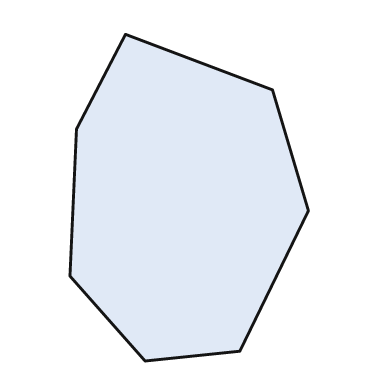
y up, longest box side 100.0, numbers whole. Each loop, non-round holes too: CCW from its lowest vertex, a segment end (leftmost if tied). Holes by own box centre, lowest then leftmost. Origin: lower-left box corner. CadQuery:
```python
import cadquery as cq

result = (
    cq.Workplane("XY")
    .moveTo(23.0, 0.0)
    .lineTo(52.0, 3.0)
    .lineTo(73.0, 46.0)
    .lineTo(62.0, 83.0)
    .lineTo(17.0, 100.0)
    .lineTo(2.0, 71.0)
    .lineTo(0.0, 26.0)
    .close()
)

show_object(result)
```